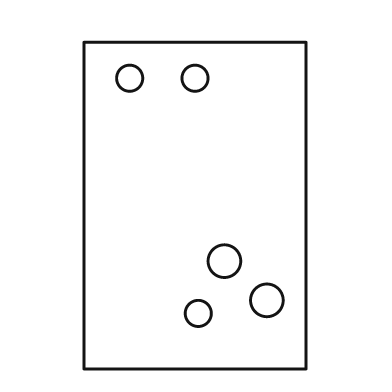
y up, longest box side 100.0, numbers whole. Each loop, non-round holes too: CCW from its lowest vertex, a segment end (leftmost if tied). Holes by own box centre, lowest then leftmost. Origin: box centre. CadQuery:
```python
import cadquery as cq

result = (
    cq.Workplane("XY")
    .moveTo(-34.0, -50.0)
    .lineTo(34.0, -50.0)
    .lineTo(34.0, 50.0)
    .lineTo(-34.0, 50.0)
    .close()
    .moveTo(1.0, -33.0)
    .circle(4.0)
    .moveTo(22.0, -29.0)
    .circle(5.0)
    .moveTo(9.0, -17.0)
    .circle(5.0)
    .moveTo(-20.0, 39.0)
    .circle(4.0)
    .moveTo(0.0, 39.0)
    .circle(4.0)
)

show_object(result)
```